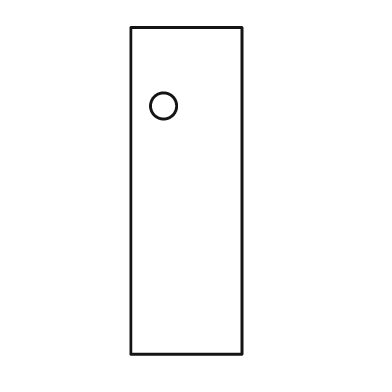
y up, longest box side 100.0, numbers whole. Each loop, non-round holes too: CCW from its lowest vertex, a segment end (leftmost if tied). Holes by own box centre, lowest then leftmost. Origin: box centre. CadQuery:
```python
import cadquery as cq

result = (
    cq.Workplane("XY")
    .moveTo(-17.0, -50.0)
    .lineTo(17.0, -50.0)
    .lineTo(17.0, 50.0)
    .lineTo(-17.0, 50.0)
    .close()
    .moveTo(-7.0, 26.0)
    .circle(4.0)
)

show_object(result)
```